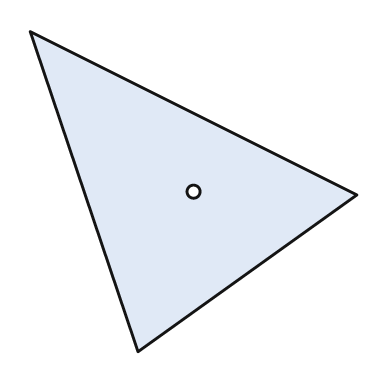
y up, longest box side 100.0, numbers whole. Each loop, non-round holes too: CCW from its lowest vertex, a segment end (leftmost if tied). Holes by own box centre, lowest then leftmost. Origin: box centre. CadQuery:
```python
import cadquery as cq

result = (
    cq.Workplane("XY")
    .moveTo(-17.0, -49.0)
    .lineTo(50.0, -1.0)
    .lineTo(-50.0, 49.0)
    .close()
    .moveTo(0.0, 0.0)
    .circle(2.0)
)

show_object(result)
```